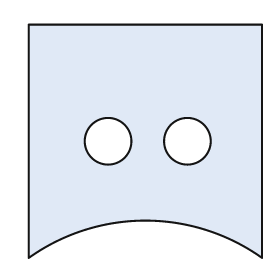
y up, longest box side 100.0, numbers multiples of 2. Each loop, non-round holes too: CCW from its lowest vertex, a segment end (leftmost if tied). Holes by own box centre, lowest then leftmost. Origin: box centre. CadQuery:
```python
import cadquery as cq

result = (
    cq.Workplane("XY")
    .moveTo(-50.0, -50.0)
    .threePointArc((0.0, -34.0), (50.0, -50.0))
    .lineTo(50.0, 50.0)
    .lineTo(-50.0, 50.0)
    .close()
    .moveTo(-16.0, 0.0)
    .circle(10.0)
    .moveTo(18.0, 0.0)
    .circle(10.0)
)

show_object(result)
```